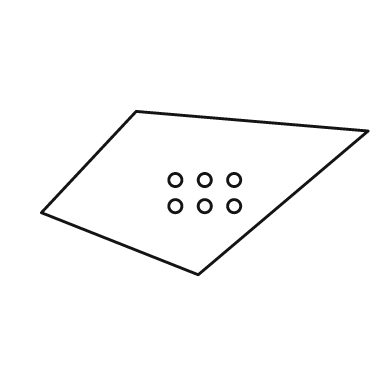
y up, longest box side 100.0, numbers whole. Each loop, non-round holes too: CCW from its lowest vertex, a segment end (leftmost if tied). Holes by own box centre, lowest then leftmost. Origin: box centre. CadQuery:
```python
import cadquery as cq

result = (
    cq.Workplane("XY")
    .moveTo(-2.0, -25.0)
    .lineTo(50.0, 19.0)
    .lineTo(-21.0, 25.0)
    .lineTo(-50.0, -6.0)
    .close()
    .moveTo(-9.0, -4.0)
    .circle(2.0)
    .moveTo(0.0, -4.0)
    .circle(2.0)
    .moveTo(9.0, -4.0)
    .circle(2.0)
    .moveTo(-9.0, 4.0)
    .circle(2.0)
    .moveTo(0.0, 4.0)
    .circle(2.0)
    .moveTo(9.0, 4.0)
    .circle(2.0)
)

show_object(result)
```